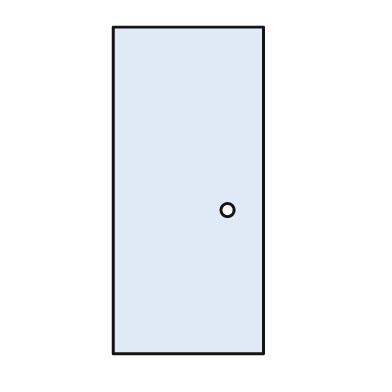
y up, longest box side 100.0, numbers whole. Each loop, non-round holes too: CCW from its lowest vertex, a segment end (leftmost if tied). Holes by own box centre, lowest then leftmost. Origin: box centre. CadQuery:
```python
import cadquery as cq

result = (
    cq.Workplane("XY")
    .moveTo(-23.0, -50.0)
    .lineTo(23.0, -50.0)
    .lineTo(23.0, 50.0)
    .lineTo(-23.0, 50.0)
    .close()
    .moveTo(12.0, -6.0)
    .circle(2.0)
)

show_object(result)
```